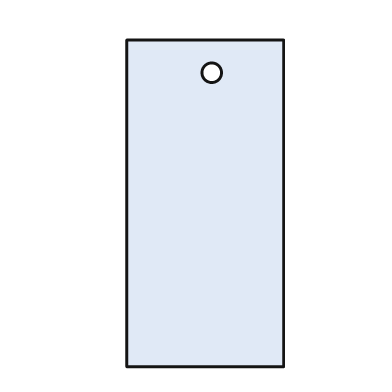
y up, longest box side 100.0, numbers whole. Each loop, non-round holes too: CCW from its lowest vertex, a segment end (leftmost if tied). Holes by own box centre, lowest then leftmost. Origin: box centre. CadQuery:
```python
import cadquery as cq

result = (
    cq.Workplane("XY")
    .moveTo(-24.0, -50.0)
    .lineTo(24.0, -50.0)
    .lineTo(24.0, 50.0)
    .lineTo(-24.0, 50.0)
    .close()
    .moveTo(2.0, 40.0)
    .circle(3.0)
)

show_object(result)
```